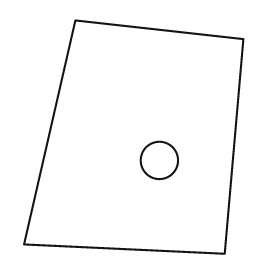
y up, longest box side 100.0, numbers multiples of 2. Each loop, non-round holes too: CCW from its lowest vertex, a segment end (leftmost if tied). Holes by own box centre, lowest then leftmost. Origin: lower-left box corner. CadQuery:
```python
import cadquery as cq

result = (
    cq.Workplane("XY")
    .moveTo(86.0, 0.0)
    .lineTo(94.0, 92.0)
    .lineTo(22.0, 100.0)
    .lineTo(0.0, 4.0)
    .close()
    .moveTo(58.0, 40.0)
    .circle(8.0)
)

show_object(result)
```